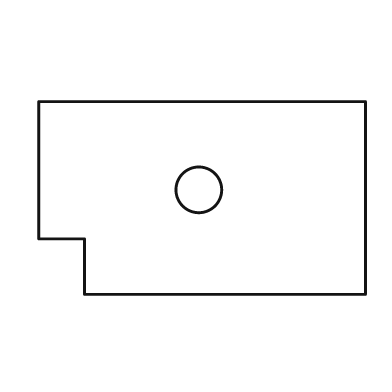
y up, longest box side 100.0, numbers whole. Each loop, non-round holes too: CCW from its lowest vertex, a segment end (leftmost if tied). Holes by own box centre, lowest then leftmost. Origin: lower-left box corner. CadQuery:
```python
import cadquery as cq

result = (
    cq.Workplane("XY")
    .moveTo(14.0, 0.0)
    .lineTo(100.0, 0.0)
    .lineTo(100.0, 59.0)
    .lineTo(0.0, 59.0)
    .lineTo(0.0, 17.0)
    .lineTo(14.0, 17.0)
    .close()
    .moveTo(49.0, 32.0)
    .circle(7.0)
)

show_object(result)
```